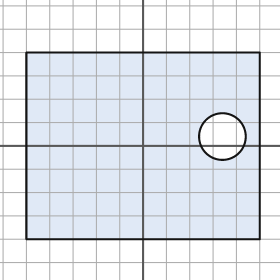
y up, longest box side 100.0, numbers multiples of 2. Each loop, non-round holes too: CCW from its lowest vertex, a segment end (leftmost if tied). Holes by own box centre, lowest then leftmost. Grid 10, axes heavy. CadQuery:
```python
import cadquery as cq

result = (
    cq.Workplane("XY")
    .moveTo(-50.0, -40.0)
    .lineTo(50.0, -40.0)
    .lineTo(50.0, 40.0)
    .lineTo(-50.0, 40.0)
    .close()
    .moveTo(34.0, 4.0)
    .circle(10.0)
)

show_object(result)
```